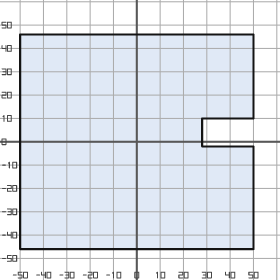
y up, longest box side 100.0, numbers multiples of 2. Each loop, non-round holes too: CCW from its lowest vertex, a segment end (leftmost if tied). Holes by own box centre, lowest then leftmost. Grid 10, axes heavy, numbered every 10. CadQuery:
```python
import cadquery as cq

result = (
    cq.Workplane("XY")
    .moveTo(-50.0, -46.0)
    .lineTo(50.0, -46.0)
    .lineTo(50.0, -2.0)
    .lineTo(28.0, -2.0)
    .lineTo(28.0, 10.0)
    .lineTo(50.0, 10.0)
    .lineTo(50.0, 46.0)
    .lineTo(-50.0, 46.0)
    .close()
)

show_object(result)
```